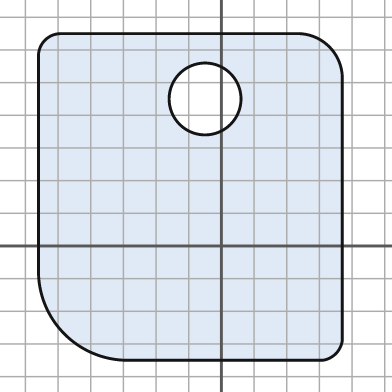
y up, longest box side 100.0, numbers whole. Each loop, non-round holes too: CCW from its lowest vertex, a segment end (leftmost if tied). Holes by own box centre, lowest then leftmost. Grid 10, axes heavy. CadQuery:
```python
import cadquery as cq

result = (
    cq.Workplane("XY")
    .moveTo(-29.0, -35.0)
    .lineTo(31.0, -35.0)
    .threePointArc((35.0, -33.0), (37.0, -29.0))
    .lineTo(37.0, 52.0)
    .threePointArc((33.0, 61.0), (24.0, 65.0))
    .lineTo(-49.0, 65.0)
    .threePointArc((-54.0, 63.0), (-56.0, 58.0))
    .lineTo(-56.0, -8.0)
    .threePointArc((-48.0, -27.0), (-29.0, -35.0))
    .close()
    .moveTo(-5.0, 45.0)
    .circle(11.0)
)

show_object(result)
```